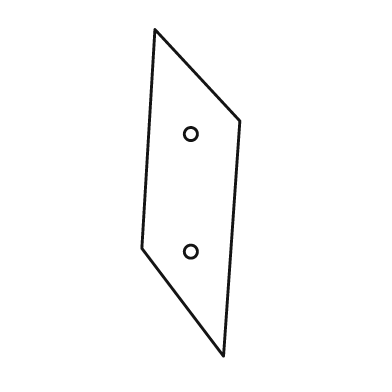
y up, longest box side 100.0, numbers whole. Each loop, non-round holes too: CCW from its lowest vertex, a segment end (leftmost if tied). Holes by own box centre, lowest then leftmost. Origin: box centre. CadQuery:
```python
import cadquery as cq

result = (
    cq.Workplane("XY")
    .moveTo(10.0, -50.0)
    .lineTo(15.0, 22.0)
    .lineTo(-11.0, 50.0)
    .lineTo(-15.0, -17.0)
    .close()
    .moveTo(0.0, -18.0)
    .circle(2.0)
    .moveTo(0.0, 18.0)
    .circle(2.0)
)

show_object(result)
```